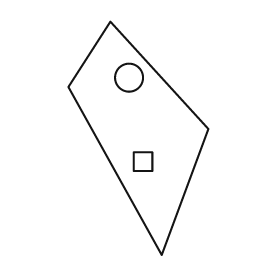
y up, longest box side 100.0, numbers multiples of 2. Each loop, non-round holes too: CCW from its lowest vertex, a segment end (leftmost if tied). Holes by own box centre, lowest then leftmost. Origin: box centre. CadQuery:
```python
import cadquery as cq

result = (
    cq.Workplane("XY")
    .moveTo(10.0, -50.0)
    .lineTo(30.0, 4.0)
    .lineTo(-12.0, 50.0)
    .lineTo(-30.0, 22.0)
    .close()
    .moveTo(-2.0, -14.0)
    .lineTo(6.0, -14.0)
    .lineTo(6.0, -6.0)
    .lineTo(-2.0, -6.0)
    .close()
    .moveTo(-4.0, 26.0)
    .circle(6.0)
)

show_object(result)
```